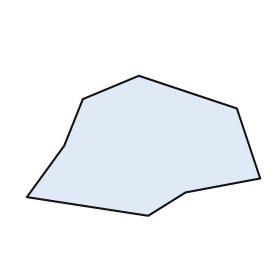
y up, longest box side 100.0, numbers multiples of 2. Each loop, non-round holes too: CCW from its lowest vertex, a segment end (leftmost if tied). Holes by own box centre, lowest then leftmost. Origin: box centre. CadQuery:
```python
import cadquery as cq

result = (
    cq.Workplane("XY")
    .moveTo(2.0, -30.0)
    .lineTo(18.0, -20.0)
    .lineTo(50.0, -14.0)
    .lineTo(40.0, 16.0)
    .lineTo(-2.0, 30.0)
    .lineTo(-26.0, 20.0)
    .lineTo(-34.0, 0.0)
    .lineTo(-50.0, -22.0)
    .close()
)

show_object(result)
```